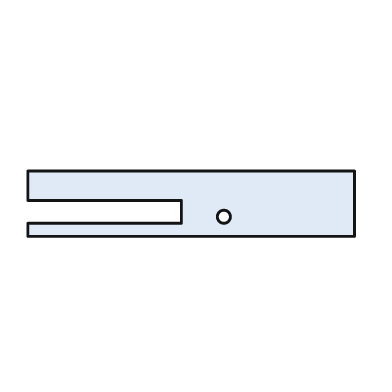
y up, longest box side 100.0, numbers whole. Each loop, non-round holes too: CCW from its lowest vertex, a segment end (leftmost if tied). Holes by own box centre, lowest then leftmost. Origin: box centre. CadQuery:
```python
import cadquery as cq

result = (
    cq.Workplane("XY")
    .moveTo(-50.0, -10.0)
    .lineTo(50.0, -10.0)
    .lineTo(50.0, 10.0)
    .lineTo(-50.0, 10.0)
    .lineTo(-50.0, 1.0)
    .lineTo(-3.0, 1.0)
    .lineTo(-3.0, -6.0)
    .lineTo(-50.0, -6.0)
    .close()
    .moveTo(10.0, -4.0)
    .circle(2.0)
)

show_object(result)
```